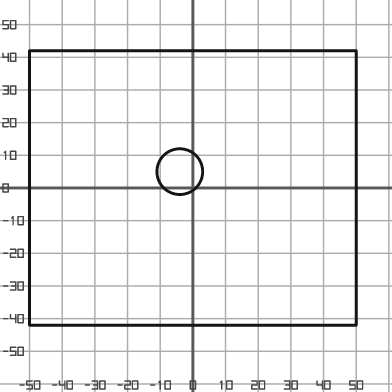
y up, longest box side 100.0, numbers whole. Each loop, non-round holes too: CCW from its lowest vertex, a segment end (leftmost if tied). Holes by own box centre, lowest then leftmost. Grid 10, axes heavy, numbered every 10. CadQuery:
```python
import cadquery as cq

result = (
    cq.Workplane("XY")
    .moveTo(-50.0, -42.0)
    .lineTo(50.0, -42.0)
    .lineTo(50.0, 42.0)
    .lineTo(-50.0, 42.0)
    .close()
    .moveTo(-4.0, 5.0)
    .circle(7.0)
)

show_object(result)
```